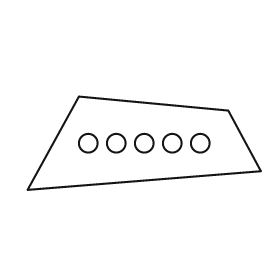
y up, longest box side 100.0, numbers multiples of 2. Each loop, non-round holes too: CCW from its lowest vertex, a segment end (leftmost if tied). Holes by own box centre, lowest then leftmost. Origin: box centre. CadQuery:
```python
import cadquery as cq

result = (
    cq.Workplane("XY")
    .moveTo(-50.0, -20.0)
    .lineTo(50.0, -12.0)
    .lineTo(36.0, 14.0)
    .lineTo(-28.0, 20.0)
    .close()
    .moveTo(-24.0, 0.0)
    .circle(4.0)
    .moveTo(-12.0, 0.0)
    .circle(4.0)
    .moveTo(0.0, 0.0)
    .circle(4.0)
    .moveTo(12.0, 0.0)
    .circle(4.0)
    .moveTo(24.0, 0.0)
    .circle(4.0)
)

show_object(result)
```